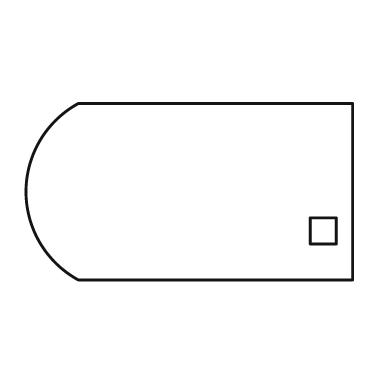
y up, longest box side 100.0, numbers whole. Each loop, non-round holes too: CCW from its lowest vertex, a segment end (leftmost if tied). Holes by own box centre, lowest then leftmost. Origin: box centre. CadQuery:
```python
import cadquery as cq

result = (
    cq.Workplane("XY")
    .moveTo(-34.0, -27.0)
    .lineTo(50.0, -27.0)
    .lineTo(50.0, 27.0)
    .lineTo(-34.0, 27.0)
    .threePointArc((-50.0, 0.0), (-34.0, -27.0))
    .close()
    .moveTo(37.0, -16.0)
    .lineTo(45.0, -16.0)
    .lineTo(45.0, -8.0)
    .lineTo(37.0, -8.0)
    .close()
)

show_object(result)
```